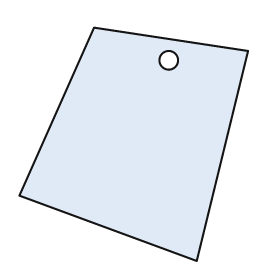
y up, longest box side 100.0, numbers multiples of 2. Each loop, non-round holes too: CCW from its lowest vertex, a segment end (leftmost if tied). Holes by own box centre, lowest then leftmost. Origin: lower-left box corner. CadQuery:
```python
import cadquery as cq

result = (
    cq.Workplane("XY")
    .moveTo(76.0, 0.0)
    .lineTo(98.0, 90.0)
    .lineTo(32.0, 100.0)
    .lineTo(0.0, 28.0)
    .close()
    .moveTo(64.0, 86.0)
    .circle(4.0)
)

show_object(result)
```